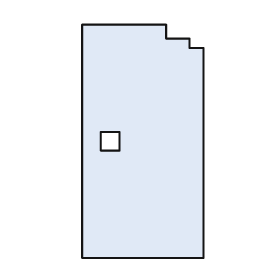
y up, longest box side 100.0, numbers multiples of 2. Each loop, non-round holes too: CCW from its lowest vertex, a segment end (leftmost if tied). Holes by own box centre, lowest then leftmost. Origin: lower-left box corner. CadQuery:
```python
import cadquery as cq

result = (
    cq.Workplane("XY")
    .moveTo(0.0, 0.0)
    .lineTo(52.0, 0.0)
    .lineTo(52.0, 90.0)
    .lineTo(46.0, 90.0)
    .lineTo(46.0, 94.0)
    .lineTo(36.0, 94.0)
    .lineTo(36.0, 100.0)
    .lineTo(0.0, 100.0)
    .close()
    .moveTo(8.0, 46.0)
    .lineTo(16.0, 46.0)
    .lineTo(16.0, 54.0)
    .lineTo(8.0, 54.0)
    .close()
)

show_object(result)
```